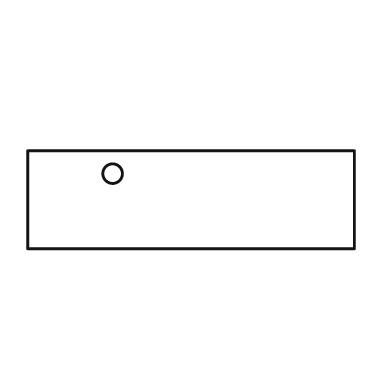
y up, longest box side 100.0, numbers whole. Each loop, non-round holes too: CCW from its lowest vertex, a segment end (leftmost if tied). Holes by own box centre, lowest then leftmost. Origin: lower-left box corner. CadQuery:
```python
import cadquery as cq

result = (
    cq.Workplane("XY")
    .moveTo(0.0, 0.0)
    .lineTo(100.0, 0.0)
    .lineTo(100.0, 30.0)
    .lineTo(0.0, 30.0)
    .close()
    .moveTo(26.0, 23.0)
    .circle(3.0)
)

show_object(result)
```